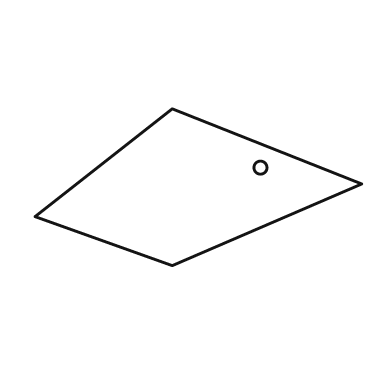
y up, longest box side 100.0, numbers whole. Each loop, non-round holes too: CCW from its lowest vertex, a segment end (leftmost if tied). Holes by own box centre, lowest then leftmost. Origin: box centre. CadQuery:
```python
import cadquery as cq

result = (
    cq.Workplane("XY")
    .moveTo(-8.0, -24.0)
    .lineTo(50.0, 1.0)
    .lineTo(-8.0, 24.0)
    .lineTo(-50.0, -9.0)
    .close()
    .moveTo(19.0, 6.0)
    .circle(2.0)
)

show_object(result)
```